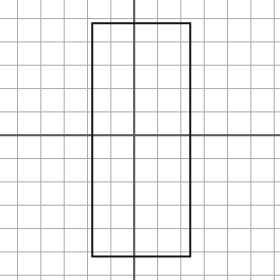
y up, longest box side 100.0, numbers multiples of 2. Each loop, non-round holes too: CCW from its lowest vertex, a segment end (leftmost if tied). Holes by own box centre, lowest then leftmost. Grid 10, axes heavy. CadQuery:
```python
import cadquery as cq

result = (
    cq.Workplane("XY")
    .moveTo(-18.0, -52.0)
    .lineTo(24.0, -52.0)
    .lineTo(24.0, 48.0)
    .lineTo(-18.0, 48.0)
    .close()
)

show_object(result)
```